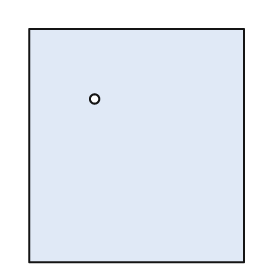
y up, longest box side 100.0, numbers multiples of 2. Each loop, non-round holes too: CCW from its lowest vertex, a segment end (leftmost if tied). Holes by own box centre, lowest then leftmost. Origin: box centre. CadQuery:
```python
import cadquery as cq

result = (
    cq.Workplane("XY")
    .moveTo(-46.0, -50.0)
    .lineTo(46.0, -50.0)
    .lineTo(46.0, 50.0)
    .lineTo(-46.0, 50.0)
    .close()
    .moveTo(-18.0, 20.0)
    .circle(2.0)
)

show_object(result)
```